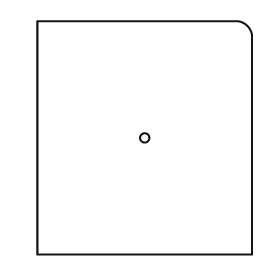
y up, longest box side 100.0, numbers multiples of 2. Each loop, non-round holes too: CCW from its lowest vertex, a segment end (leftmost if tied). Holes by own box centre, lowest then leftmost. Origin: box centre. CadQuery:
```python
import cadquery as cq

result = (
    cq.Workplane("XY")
    .moveTo(-46.0, -50.0)
    .lineTo(46.0, -50.0)
    .lineTo(46.0, 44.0)
    .threePointArc((44.0, 48.0), (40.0, 50.0))
    .lineTo(-46.0, 50.0)
    .close()
    .moveTo(0.0, 0.0)
    .circle(2.0)
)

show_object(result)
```